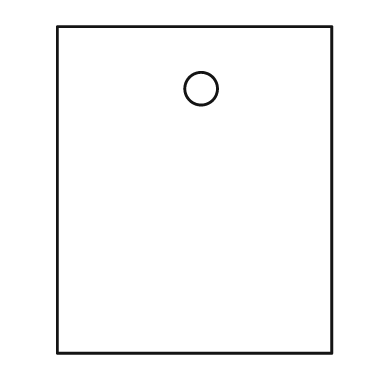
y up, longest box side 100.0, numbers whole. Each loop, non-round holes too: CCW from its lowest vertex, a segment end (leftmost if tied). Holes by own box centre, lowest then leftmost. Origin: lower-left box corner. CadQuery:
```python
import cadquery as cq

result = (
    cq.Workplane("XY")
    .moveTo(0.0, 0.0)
    .lineTo(84.0, 0.0)
    .lineTo(84.0, 100.0)
    .lineTo(0.0, 100.0)
    .close()
    .moveTo(44.0, 81.0)
    .circle(5.0)
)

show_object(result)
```